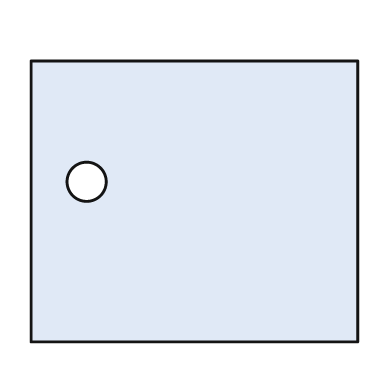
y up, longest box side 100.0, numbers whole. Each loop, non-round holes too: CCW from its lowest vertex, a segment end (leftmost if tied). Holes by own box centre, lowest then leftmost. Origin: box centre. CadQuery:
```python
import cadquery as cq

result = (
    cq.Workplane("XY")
    .moveTo(-50.0, -43.0)
    .lineTo(50.0, -43.0)
    .lineTo(50.0, 43.0)
    .lineTo(-50.0, 43.0)
    .close()
    .moveTo(-33.0, 6.0)
    .circle(6.0)
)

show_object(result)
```